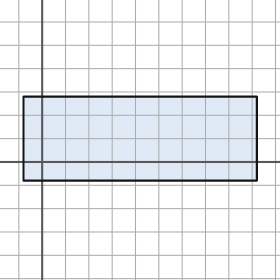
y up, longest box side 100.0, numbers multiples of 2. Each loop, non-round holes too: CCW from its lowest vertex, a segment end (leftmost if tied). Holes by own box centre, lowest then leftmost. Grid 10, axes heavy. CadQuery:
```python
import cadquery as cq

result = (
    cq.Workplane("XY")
    .moveTo(-8.0, -8.0)
    .lineTo(92.0, -8.0)
    .lineTo(92.0, 28.0)
    .lineTo(-8.0, 28.0)
    .close()
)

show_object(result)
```